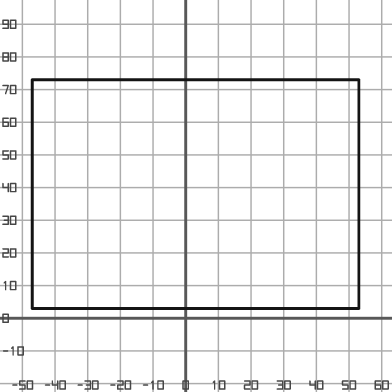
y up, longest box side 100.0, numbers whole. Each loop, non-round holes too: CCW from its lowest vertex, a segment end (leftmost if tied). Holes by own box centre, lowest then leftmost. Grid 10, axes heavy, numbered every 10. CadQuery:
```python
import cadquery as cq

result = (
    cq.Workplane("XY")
    .moveTo(-47.0, 3.0)
    .lineTo(53.0, 3.0)
    .lineTo(53.0, 73.0)
    .lineTo(-47.0, 73.0)
    .close()
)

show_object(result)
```